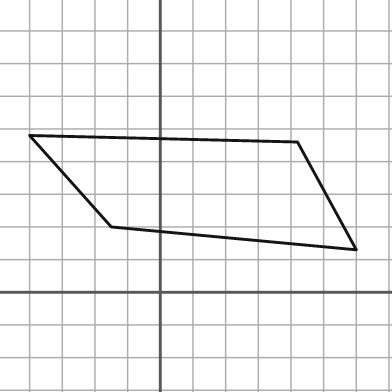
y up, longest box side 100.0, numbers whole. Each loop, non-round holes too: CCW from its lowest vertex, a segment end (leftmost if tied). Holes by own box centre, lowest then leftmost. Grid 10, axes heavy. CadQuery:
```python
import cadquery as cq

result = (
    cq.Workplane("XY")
    .moveTo(60.0, 13.0)
    .lineTo(42.0, 46.0)
    .lineTo(-40.0, 48.0)
    .lineTo(-15.0, 20.0)
    .close()
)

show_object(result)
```